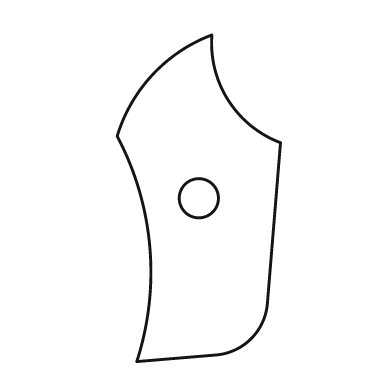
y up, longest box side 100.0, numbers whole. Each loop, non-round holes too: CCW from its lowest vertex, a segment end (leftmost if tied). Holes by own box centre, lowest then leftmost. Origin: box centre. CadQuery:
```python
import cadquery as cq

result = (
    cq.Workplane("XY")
    .moveTo(-19.0, -50.0)
    .lineTo(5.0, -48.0)
    .threePointArc((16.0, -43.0), (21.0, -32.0))
    .lineTo(25.0, 17.0)
    .threePointArc((9.0, 30.0), (4.0, 50.0))
    .threePointArc((-14.0, 38.0), (-25.0, 19.0))
    .threePointArc((-15.0, -15.0), (-19.0, -50.0))
    .close()
    .moveTo(0.0, 0.0)
    .circle(6.0)
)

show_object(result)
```